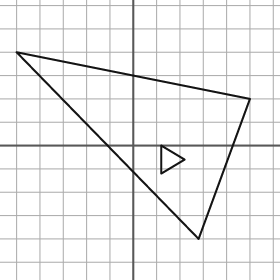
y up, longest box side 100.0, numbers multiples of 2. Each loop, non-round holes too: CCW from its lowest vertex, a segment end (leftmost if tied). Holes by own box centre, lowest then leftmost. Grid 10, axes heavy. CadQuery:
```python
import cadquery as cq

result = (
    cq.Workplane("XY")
    .moveTo(28.0, -40.0)
    .lineTo(50.0, 20.0)
    .lineTo(-50.0, 40.0)
    .close()
    .moveTo(12.0, -12.0)
    .lineTo(22.0, -6.0)
    .lineTo(12.0, 0.0)
    .close()
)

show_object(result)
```